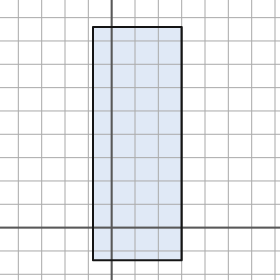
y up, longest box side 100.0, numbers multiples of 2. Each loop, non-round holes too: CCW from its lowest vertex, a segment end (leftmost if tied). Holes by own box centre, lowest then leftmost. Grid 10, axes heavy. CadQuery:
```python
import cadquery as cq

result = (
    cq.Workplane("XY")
    .moveTo(-8.0, -14.0)
    .lineTo(30.0, -14.0)
    .lineTo(30.0, 86.0)
    .lineTo(-8.0, 86.0)
    .close()
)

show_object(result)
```